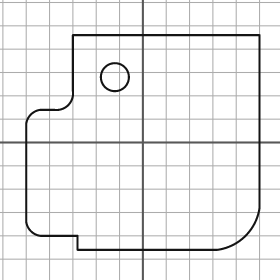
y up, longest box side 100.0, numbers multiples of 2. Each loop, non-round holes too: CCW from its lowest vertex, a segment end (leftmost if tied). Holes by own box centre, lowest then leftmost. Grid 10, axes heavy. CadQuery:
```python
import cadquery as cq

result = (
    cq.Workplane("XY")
    .moveTo(-28.0, -46.0)
    .lineTo(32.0, -46.0)
    .threePointArc((44.0, -40.0), (50.0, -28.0))
    .lineTo(50.0, 46.0)
    .lineTo(-30.0, 46.0)
    .lineTo(-30.0, 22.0)
    .threePointArc((-32.0, 16.0), (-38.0, 14.0))
    .lineTo(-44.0, 14.0)
    .threePointArc((-48.0, 12.0), (-50.0, 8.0))
    .lineTo(-50.0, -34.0)
    .threePointArc((-48.0, -38.0), (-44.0, -40.0))
    .lineTo(-28.0, -40.0)
    .close()
    .moveTo(-12.0, 28.0)
    .circle(6.0)
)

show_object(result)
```